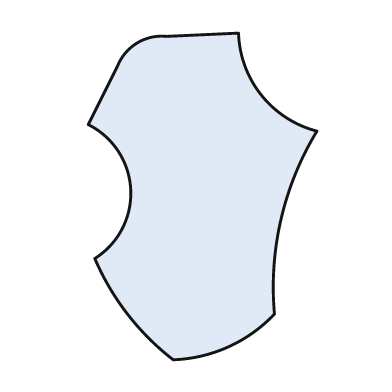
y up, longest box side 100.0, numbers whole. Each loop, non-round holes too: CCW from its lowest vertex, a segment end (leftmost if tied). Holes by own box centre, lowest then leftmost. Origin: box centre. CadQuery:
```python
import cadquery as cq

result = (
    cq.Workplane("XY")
    .moveTo(-9.0, -50.0)
    .threePointArc((8.0, -46.0), (22.0, -36.0))
    .threePointArc((24.0, -7.0), (35.0, 20.0))
    .threePointArc((18.0, 31.0), (11.0, 50.0))
    .lineTo(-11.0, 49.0)
    .threePointArc((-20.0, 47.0), (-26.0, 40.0))
    .lineTo(-35.0, 22.0)
    .threePointArc((-22.0, 2.0), (-33.0, -19.0))
    .threePointArc((-23.0, -36.0), (-9.0, -50.0))
    .close()
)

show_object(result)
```